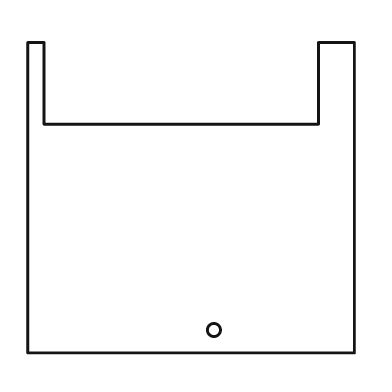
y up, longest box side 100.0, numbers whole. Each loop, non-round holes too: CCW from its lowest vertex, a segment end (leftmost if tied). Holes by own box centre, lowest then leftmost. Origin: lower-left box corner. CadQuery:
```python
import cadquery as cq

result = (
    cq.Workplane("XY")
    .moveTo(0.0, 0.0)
    .lineTo(100.0, 0.0)
    .lineTo(100.0, 95.0)
    .lineTo(89.0, 95.0)
    .lineTo(89.0, 70.0)
    .lineTo(5.0, 70.0)
    .lineTo(5.0, 95.0)
    .lineTo(0.0, 95.0)
    .close()
    .moveTo(57.0, 7.0)
    .circle(2.0)
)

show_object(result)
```